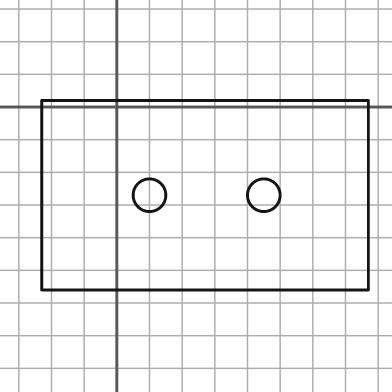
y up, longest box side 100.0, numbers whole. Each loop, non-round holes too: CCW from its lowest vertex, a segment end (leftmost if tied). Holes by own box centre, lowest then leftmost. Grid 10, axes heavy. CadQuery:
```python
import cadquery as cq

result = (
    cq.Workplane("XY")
    .moveTo(-23.0, -56.0)
    .lineTo(77.0, -56.0)
    .lineTo(77.0, 2.0)
    .lineTo(-23.0, 2.0)
    .close()
    .moveTo(10.0, -27.0)
    .circle(5.0)
    .moveTo(45.0, -27.0)
    .circle(5.0)
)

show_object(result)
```